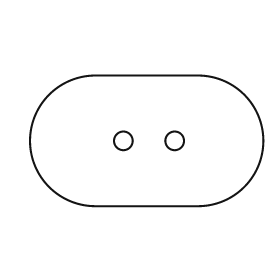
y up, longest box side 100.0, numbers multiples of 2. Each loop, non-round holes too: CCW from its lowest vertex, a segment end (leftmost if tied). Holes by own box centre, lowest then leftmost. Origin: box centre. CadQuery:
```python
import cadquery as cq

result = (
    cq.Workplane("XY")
    .moveTo(-22.0, -28.0)
    .lineTo(22.0, -28.0)
    .threePointArc((50.0, 0.0), (22.0, 28.0))
    .lineTo(-22.0, 28.0)
    .threePointArc((-50.0, 0.0), (-22.0, -28.0))
    .close()
    .moveTo(-10.0, 0.0)
    .circle(4.0)
    .moveTo(12.0, 0.0)
    .circle(4.0)
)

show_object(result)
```